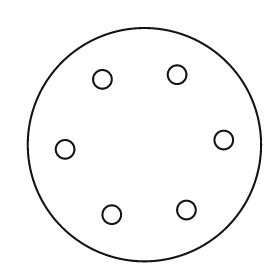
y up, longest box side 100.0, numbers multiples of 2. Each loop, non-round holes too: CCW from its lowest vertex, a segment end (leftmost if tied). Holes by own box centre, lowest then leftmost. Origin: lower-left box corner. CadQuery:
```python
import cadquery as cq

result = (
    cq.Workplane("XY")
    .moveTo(50.0, 50.0)
    .circle(50.0)
    .moveTo(36.0, 20.0)
    .circle(4.0)
    .moveTo(68.0, 22.0)
    .circle(4.0)
    .moveTo(16.0, 48.0)
    .circle(4.0)
    .moveTo(84.0, 52.0)
    .circle(4.0)
    .moveTo(32.0, 78.0)
    .circle(4.0)
    .moveTo(64.0, 80.0)
    .circle(4.0)
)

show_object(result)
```